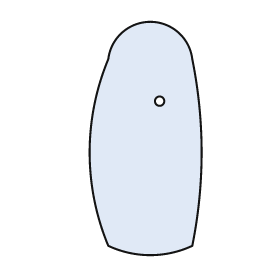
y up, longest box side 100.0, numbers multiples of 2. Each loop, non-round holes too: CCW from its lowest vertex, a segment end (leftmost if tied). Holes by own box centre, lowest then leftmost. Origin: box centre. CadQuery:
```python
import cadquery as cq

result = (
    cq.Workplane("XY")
    .moveTo(-16.0, -46.0)
    .threePointArc((2.0, -50.0), (20.0, -46.0))
    .threePointArc((24.0, -6.0), (20.0, 34.0))
    .threePointArc((2.0, 50.0), (-16.0, 34.0))
    .threePointArc((-24.0, -6.0), (-16.0, -46.0))
    .close()
    .moveTo(6.0, 16.0)
    .circle(2.0)
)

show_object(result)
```